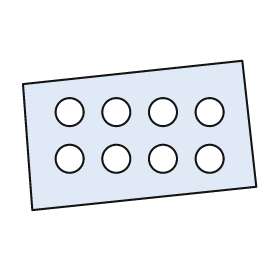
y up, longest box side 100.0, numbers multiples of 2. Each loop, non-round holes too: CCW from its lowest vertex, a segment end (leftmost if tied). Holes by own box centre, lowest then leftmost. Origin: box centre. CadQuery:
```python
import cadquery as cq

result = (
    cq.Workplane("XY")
    .moveTo(-46.0, -32.0)
    .lineTo(50.0, -22.0)
    .lineTo(44.0, 32.0)
    .lineTo(-50.0, 22.0)
    .close()
    .moveTo(-30.0, -10.0)
    .circle(6.0)
    .moveTo(-10.0, -10.0)
    .circle(6.0)
    .moveTo(10.0, -10.0)
    .circle(6.0)
    .moveTo(30.0, -10.0)
    .circle(6.0)
    .moveTo(-30.0, 10.0)
    .circle(6.0)
    .moveTo(-10.0, 10.0)
    .circle(6.0)
    .moveTo(10.0, 10.0)
    .circle(6.0)
    .moveTo(30.0, 10.0)
    .circle(6.0)
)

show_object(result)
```